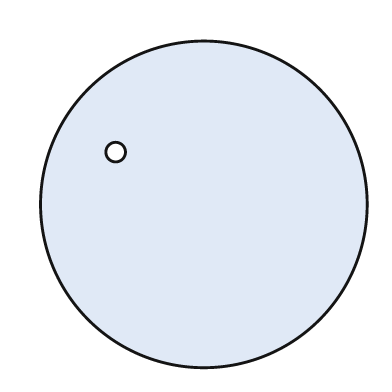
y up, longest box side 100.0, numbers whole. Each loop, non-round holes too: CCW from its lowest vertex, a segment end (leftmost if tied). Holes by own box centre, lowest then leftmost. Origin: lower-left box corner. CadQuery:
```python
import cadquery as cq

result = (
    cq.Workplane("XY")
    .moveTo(50.0, 50.0)
    .circle(50.0)
    .moveTo(23.0, 66.0)
    .circle(3.0)
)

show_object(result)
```